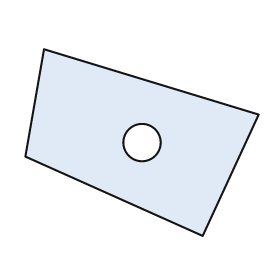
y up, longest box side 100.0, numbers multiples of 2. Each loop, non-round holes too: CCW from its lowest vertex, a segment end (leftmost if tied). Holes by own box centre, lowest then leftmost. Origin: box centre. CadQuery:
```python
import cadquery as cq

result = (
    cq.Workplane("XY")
    .moveTo(26.0, -40.0)
    .lineTo(50.0, 12.0)
    .lineTo(-42.0, 40.0)
    .lineTo(-50.0, -6.0)
    .close()
    .moveTo(0.0, 0.0)
    .circle(8.0)
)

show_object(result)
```